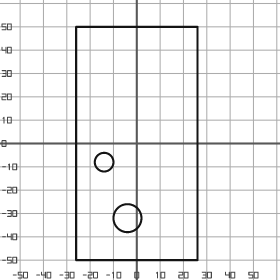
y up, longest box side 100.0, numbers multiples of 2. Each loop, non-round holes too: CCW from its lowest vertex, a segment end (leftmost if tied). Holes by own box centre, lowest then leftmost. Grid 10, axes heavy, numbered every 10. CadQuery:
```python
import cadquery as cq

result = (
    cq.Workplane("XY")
    .moveTo(-26.0, -50.0)
    .lineTo(26.0, -50.0)
    .lineTo(26.0, 50.0)
    .lineTo(-26.0, 50.0)
    .close()
    .moveTo(-4.0, -32.0)
    .circle(6.0)
    .moveTo(-14.0, -8.0)
    .circle(4.0)
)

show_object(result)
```